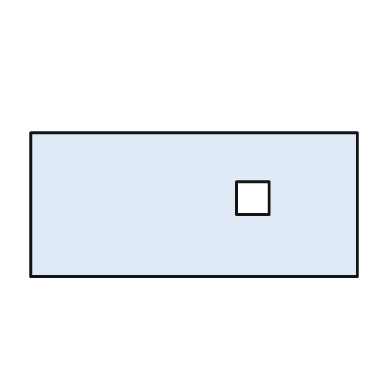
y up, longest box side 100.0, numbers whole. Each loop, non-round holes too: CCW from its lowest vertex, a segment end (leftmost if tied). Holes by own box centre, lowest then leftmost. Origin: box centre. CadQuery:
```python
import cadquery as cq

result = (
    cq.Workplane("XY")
    .moveTo(-50.0, -22.0)
    .lineTo(50.0, -22.0)
    .lineTo(50.0, 22.0)
    .lineTo(-50.0, 22.0)
    .close()
    .moveTo(13.0, -3.0)
    .lineTo(23.0, -3.0)
    .lineTo(23.0, 7.0)
    .lineTo(13.0, 7.0)
    .close()
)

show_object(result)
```